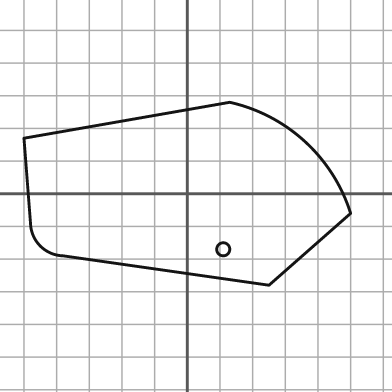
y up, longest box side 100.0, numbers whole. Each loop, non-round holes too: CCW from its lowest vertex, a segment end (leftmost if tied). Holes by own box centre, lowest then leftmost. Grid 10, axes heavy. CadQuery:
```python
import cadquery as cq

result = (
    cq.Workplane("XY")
    .moveTo(25.0, -28.0)
    .lineTo(50.0, -6.0)
    .threePointArc((36.0, 16.0), (13.0, 28.0))
    .lineTo(-50.0, 17.0)
    .lineTo(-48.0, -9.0)
    .threePointArc((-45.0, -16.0), (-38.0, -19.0))
    .close()
    .moveTo(11.0, -17.0)
    .circle(2.0)
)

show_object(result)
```